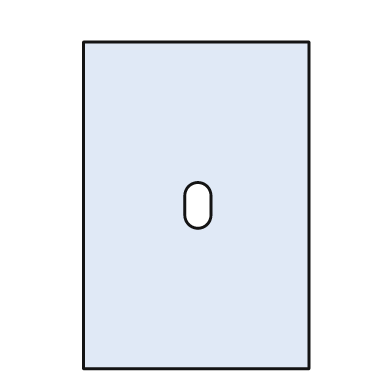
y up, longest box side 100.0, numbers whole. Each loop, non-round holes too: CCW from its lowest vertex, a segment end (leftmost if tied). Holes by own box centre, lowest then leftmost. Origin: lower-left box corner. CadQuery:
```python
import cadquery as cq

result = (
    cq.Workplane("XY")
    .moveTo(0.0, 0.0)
    .lineTo(69.0, 0.0)
    .lineTo(69.0, 100.0)
    .lineTo(0.0, 100.0)
    .close()
    .moveTo(31.0, 47.0)
    .threePointArc((35.0, 43.0), (39.0, 47.0))
    .lineTo(39.0, 53.0)
    .threePointArc((35.0, 57.0), (31.0, 53.0))
    .close()
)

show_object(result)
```